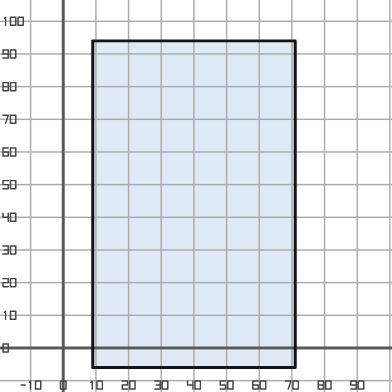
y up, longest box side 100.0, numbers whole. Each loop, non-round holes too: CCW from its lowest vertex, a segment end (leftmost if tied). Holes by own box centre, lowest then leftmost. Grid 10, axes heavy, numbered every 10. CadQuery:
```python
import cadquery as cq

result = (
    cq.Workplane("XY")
    .moveTo(9.0, -6.0)
    .lineTo(71.0, -6.0)
    .lineTo(71.0, 94.0)
    .lineTo(9.0, 94.0)
    .close()
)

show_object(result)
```